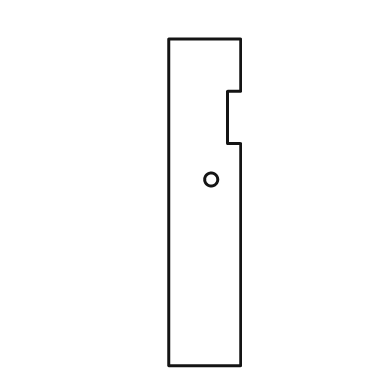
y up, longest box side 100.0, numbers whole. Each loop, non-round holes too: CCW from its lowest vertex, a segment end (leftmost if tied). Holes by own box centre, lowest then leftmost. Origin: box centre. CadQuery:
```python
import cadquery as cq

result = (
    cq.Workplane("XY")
    .moveTo(-11.0, -50.0)
    .lineTo(11.0, -50.0)
    .lineTo(11.0, 18.0)
    .lineTo(7.0, 18.0)
    .lineTo(7.0, 34.0)
    .lineTo(11.0, 34.0)
    .lineTo(11.0, 50.0)
    .lineTo(-11.0, 50.0)
    .close()
    .moveTo(2.0, 7.0)
    .circle(2.0)
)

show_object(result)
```